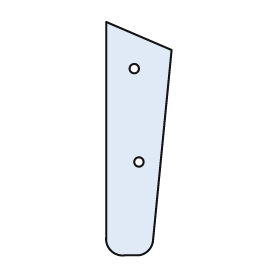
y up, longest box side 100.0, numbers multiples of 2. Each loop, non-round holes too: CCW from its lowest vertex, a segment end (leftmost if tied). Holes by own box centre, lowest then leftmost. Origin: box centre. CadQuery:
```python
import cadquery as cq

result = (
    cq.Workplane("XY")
    .moveTo(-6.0, -50.0)
    .lineTo(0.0, -50.0)
    .threePointArc((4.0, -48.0), (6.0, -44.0))
    .lineTo(14.0, 38.0)
    .lineTo(-14.0, 50.0)
    .lineTo(-14.0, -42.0)
    .threePointArc((-12.0, -48.0), (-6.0, -50.0))
    .close()
    .moveTo(0.0, -10.0)
    .circle(2.0)
    .moveTo(-2.0, 30.0)
    .circle(2.0)
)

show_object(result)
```